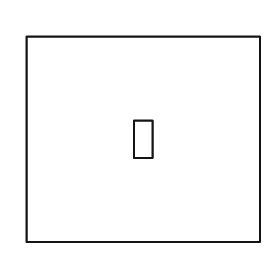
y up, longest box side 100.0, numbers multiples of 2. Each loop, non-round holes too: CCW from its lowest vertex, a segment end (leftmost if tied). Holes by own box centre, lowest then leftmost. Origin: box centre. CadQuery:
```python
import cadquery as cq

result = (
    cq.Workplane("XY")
    .moveTo(-50.0, -44.0)
    .lineTo(50.0, -44.0)
    .lineTo(50.0, 44.0)
    .lineTo(-50.0, 44.0)
    .close()
    .moveTo(-4.0, -8.0)
    .lineTo(4.0, -8.0)
    .lineTo(4.0, 8.0)
    .lineTo(-4.0, 8.0)
    .close()
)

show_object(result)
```